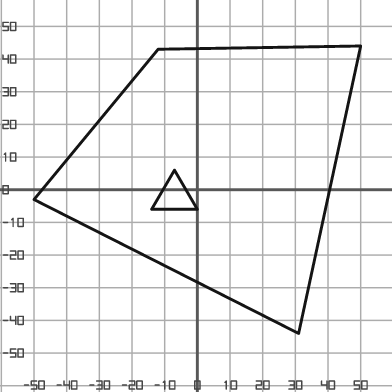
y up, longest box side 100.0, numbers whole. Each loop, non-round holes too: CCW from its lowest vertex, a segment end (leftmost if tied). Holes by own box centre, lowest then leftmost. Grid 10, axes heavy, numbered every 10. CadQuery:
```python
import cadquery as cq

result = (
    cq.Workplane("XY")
    .moveTo(31.0, -44.0)
    .lineTo(50.0, 44.0)
    .lineTo(-12.0, 43.0)
    .lineTo(-50.0, -3.0)
    .close()
    .moveTo(-14.0, -6.0)
    .lineTo(0.0, -6.0)
    .lineTo(-7.0, 6.0)
    .close()
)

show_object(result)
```